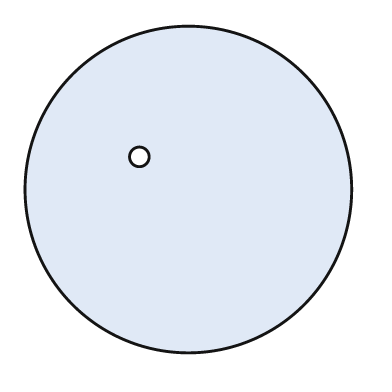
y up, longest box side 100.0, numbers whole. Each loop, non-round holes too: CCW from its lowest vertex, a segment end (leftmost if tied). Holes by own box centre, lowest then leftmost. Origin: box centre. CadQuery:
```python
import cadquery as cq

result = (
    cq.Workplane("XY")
    .moveTo(0.0, 0.0)
    .circle(50.0)
    .moveTo(-15.0, 10.0)
    .circle(3.0)
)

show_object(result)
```